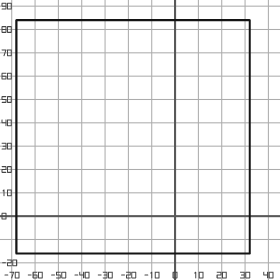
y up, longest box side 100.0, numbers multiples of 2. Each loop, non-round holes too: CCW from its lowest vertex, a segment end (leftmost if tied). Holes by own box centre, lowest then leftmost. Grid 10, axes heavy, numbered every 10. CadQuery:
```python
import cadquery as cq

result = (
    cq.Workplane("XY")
    .moveTo(-68.0, -16.0)
    .lineTo(32.0, -16.0)
    .lineTo(32.0, 84.0)
    .lineTo(-68.0, 84.0)
    .close()
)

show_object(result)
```